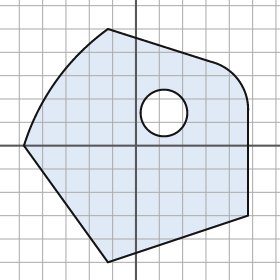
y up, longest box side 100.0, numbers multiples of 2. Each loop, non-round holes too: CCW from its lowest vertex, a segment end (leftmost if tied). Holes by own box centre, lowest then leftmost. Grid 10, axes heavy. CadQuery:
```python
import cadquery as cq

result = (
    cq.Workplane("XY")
    .moveTo(-12.0, -50.0)
    .lineTo(48.0, -30.0)
    .lineTo(48.0, 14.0)
    .threePointArc((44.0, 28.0), (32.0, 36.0))
    .lineTo(-12.0, 50.0)
    .threePointArc((-34.0, 28.0), (-48.0, 0.0))
    .close()
    .moveTo(12.0, 14.0)
    .circle(10.0)
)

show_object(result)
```